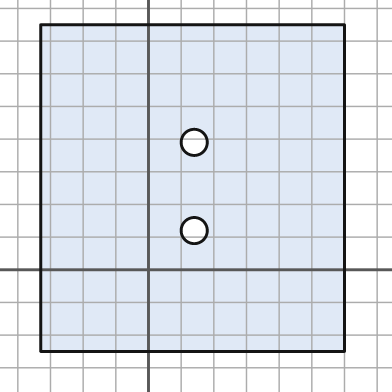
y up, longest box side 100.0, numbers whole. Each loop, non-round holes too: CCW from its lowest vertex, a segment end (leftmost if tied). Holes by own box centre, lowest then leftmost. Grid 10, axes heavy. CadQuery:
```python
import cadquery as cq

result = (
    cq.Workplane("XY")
    .moveTo(-33.0, -25.0)
    .lineTo(60.0, -25.0)
    .lineTo(60.0, 75.0)
    .lineTo(-33.0, 75.0)
    .close()
    .moveTo(14.0, 12.0)
    .circle(4.0)
    .moveTo(14.0, 39.0)
    .circle(4.0)
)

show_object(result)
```